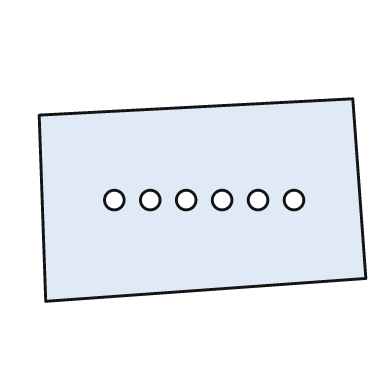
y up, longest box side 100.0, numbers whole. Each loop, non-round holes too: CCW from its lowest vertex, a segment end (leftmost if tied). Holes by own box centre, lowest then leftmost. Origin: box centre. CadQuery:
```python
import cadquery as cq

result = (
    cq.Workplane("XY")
    .moveTo(-48.0, -31.0)
    .lineTo(50.0, -24.0)
    .lineTo(46.0, 31.0)
    .lineTo(-50.0, 26.0)
    .close()
    .moveTo(-27.0, 0.0)
    .circle(3.0)
    .moveTo(-16.0, 0.0)
    .circle(3.0)
    .moveTo(-5.0, 0.0)
    .circle(3.0)
    .moveTo(6.0, 0.0)
    .circle(3.0)
    .moveTo(17.0, 0.0)
    .circle(3.0)
    .moveTo(28.0, 0.0)
    .circle(3.0)
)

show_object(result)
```